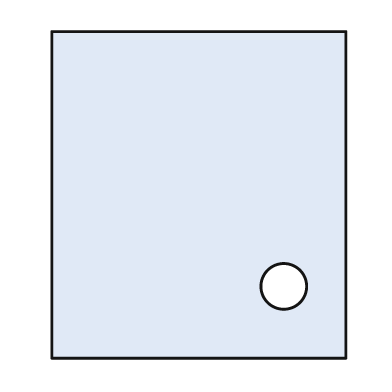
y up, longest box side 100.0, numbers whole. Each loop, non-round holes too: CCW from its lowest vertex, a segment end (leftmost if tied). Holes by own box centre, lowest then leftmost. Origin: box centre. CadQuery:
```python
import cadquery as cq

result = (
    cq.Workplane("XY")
    .moveTo(-45.0, -50.0)
    .lineTo(45.0, -50.0)
    .lineTo(45.0, 50.0)
    .lineTo(-45.0, 50.0)
    .close()
    .moveTo(26.0, -28.0)
    .circle(7.0)
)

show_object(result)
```